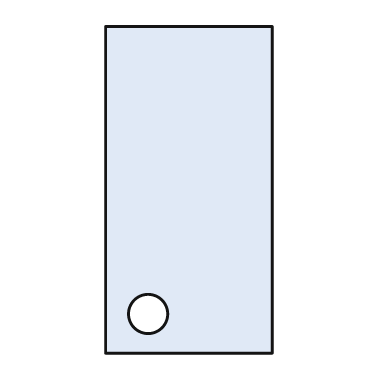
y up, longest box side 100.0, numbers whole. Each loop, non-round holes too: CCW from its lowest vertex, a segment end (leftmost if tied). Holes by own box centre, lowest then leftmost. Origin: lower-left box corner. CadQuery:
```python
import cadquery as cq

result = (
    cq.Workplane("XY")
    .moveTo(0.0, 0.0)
    .lineTo(51.0, 0.0)
    .lineTo(51.0, 100.0)
    .lineTo(0.0, 100.0)
    .close()
    .moveTo(13.0, 12.0)
    .circle(6.0)
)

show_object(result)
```